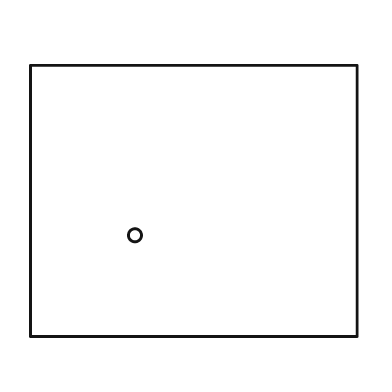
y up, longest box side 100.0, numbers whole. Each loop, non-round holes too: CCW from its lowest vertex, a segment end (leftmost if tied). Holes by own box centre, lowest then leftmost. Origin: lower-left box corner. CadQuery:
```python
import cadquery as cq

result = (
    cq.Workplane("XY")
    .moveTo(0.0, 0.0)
    .lineTo(100.0, 0.0)
    .lineTo(100.0, 83.0)
    .lineTo(0.0, 83.0)
    .close()
    .moveTo(32.0, 31.0)
    .circle(2.0)
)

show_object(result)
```